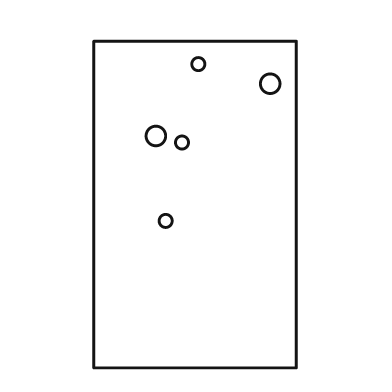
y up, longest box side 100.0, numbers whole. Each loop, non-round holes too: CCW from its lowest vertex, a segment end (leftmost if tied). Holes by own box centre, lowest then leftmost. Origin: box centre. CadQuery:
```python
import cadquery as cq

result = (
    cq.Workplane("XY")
    .moveTo(-31.0, -50.0)
    .lineTo(31.0, -50.0)
    .lineTo(31.0, 50.0)
    .lineTo(-31.0, 50.0)
    .close()
    .moveTo(-9.0, -5.0)
    .circle(2.0)
    .moveTo(-4.0, 19.0)
    .circle(2.0)
    .moveTo(-12.0, 21.0)
    .circle(3.0)
    .moveTo(23.0, 37.0)
    .circle(3.0)
    .moveTo(1.0, 43.0)
    .circle(2.0)
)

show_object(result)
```